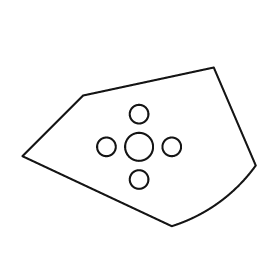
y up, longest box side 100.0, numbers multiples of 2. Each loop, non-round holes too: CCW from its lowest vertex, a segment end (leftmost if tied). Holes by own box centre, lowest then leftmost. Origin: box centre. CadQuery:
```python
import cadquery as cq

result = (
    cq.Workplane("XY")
    .moveTo(14.0, -34.0)
    .threePointArc((34.0, -24.0), (50.0, -8.0))
    .lineTo(32.0, 34.0)
    .lineTo(-24.0, 22.0)
    .lineTo(-50.0, -4.0)
    .close()
    .moveTo(0.0, -14.0)
    .circle(4.0)
    .moveTo(-14.0, 0.0)
    .circle(4.0)
    .moveTo(0.0, 0.0)
    .circle(6.0)
    .moveTo(14.0, 0.0)
    .circle(4.0)
    .moveTo(0.0, 14.0)
    .circle(4.0)
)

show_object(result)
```